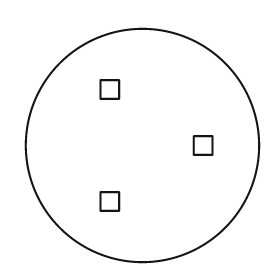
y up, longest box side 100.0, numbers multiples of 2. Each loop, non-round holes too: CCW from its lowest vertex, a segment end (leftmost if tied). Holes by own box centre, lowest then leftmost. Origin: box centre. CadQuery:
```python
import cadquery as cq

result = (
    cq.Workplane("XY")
    .moveTo(0.0, 0.0)
    .circle(50.0)
    .moveTo(-18.0, -28.0)
    .lineTo(-10.0, -28.0)
    .lineTo(-10.0, -20.0)
    .lineTo(-18.0, -20.0)
    .close()
    .moveTo(22.0, -4.0)
    .lineTo(30.0, -4.0)
    .lineTo(30.0, 4.0)
    .lineTo(22.0, 4.0)
    .close()
    .moveTo(-18.0, 20.0)
    .lineTo(-10.0, 20.0)
    .lineTo(-10.0, 28.0)
    .lineTo(-18.0, 28.0)
    .close()
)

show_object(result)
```